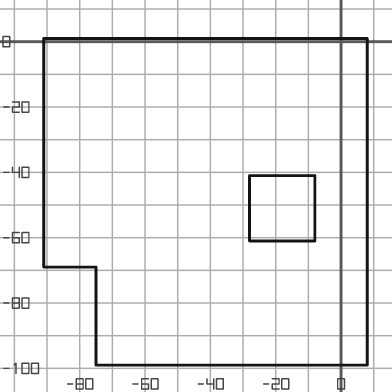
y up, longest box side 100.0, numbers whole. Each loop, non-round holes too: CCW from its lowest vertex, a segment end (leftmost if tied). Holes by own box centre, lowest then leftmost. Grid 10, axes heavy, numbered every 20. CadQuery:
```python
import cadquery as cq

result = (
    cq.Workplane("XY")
    .moveTo(-75.0, -99.0)
    .lineTo(8.0, -99.0)
    .lineTo(8.0, 1.0)
    .lineTo(-91.0, 1.0)
    .lineTo(-91.0, -69.0)
    .lineTo(-75.0, -69.0)
    .close()
    .moveTo(-28.0, -61.0)
    .lineTo(-8.0, -61.0)
    .lineTo(-8.0, -41.0)
    .lineTo(-28.0, -41.0)
    .close()
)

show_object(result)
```